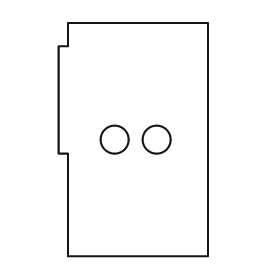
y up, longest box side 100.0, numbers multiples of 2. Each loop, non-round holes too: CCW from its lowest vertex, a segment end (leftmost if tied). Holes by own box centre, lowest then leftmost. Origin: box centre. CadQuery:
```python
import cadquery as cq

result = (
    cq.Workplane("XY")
    .moveTo(-28.0, -50.0)
    .lineTo(32.0, -50.0)
    .lineTo(32.0, 50.0)
    .lineTo(-28.0, 50.0)
    .lineTo(-28.0, 40.0)
    .lineTo(-32.0, 40.0)
    .lineTo(-32.0, -6.0)
    .lineTo(-28.0, -6.0)
    .close()
    .moveTo(-8.0, 0.0)
    .circle(6.0)
    .moveTo(10.0, 0.0)
    .circle(6.0)
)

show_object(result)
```